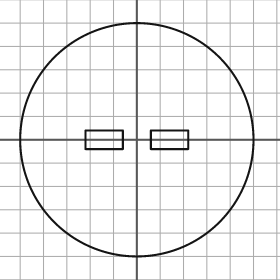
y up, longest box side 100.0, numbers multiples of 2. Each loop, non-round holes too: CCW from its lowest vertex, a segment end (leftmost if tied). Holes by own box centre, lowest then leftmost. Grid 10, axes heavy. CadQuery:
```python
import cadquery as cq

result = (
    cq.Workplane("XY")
    .moveTo(0.0, 0.0)
    .circle(50.0)
    .moveTo(-22.0, -4.0)
    .lineTo(-6.0, -4.0)
    .lineTo(-6.0, 4.0)
    .lineTo(-22.0, 4.0)
    .close()
    .moveTo(6.0, -4.0)
    .lineTo(22.0, -4.0)
    .lineTo(22.0, 4.0)
    .lineTo(6.0, 4.0)
    .close()
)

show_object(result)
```